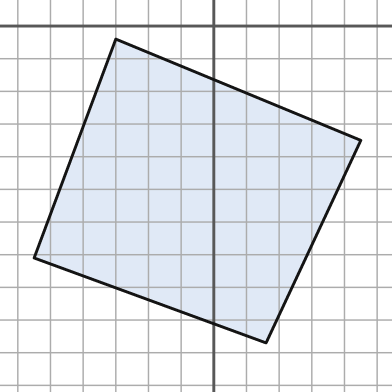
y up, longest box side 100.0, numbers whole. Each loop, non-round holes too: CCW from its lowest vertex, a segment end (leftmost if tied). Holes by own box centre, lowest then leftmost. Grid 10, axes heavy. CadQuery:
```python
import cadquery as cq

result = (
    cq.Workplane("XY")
    .moveTo(16.0, -97.0)
    .lineTo(45.0, -35.0)
    .lineTo(-30.0, -4.0)
    .lineTo(-55.0, -71.0)
    .close()
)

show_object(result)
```